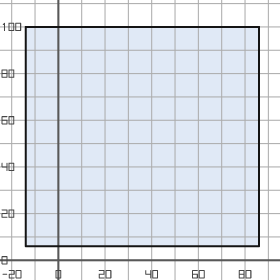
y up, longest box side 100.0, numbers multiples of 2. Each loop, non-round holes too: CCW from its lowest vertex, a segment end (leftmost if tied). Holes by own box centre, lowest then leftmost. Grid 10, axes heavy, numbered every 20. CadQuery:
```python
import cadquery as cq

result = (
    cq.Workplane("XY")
    .moveTo(-14.0, 6.0)
    .lineTo(86.0, 6.0)
    .lineTo(86.0, 100.0)
    .lineTo(-14.0, 100.0)
    .close()
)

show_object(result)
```